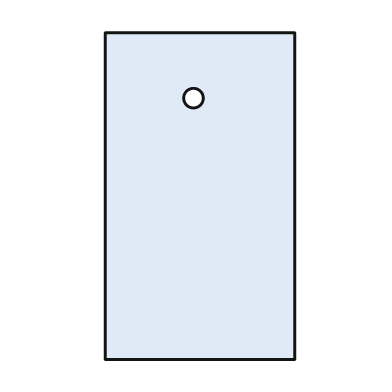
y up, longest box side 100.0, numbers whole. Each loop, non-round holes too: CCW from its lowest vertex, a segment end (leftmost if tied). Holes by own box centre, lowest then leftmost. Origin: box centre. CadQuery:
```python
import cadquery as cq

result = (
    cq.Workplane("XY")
    .moveTo(-29.0, -50.0)
    .lineTo(29.0, -50.0)
    .lineTo(29.0, 50.0)
    .lineTo(-29.0, 50.0)
    .close()
    .moveTo(-2.0, 30.0)
    .circle(3.0)
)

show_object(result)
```